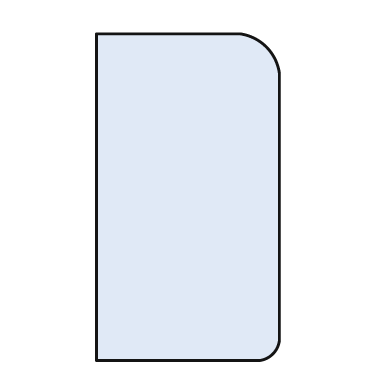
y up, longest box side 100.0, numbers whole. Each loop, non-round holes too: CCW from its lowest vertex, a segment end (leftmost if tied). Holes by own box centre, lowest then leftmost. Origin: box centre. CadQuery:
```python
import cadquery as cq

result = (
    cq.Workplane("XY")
    .moveTo(-28.0, -50.0)
    .lineTo(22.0, -50.0)
    .threePointArc((26.0, -48.0), (28.0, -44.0))
    .lineTo(28.0, 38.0)
    .threePointArc((24.0, 46.0), (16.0, 50.0))
    .lineTo(-28.0, 50.0)
    .close()
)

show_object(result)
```